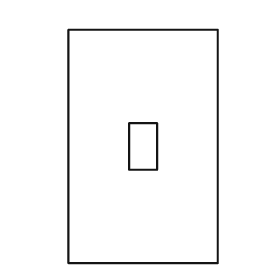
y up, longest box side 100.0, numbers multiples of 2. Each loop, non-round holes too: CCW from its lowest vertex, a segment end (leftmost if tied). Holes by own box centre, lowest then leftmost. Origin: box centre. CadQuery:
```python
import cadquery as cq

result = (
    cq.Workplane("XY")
    .moveTo(-32.0, -50.0)
    .lineTo(32.0, -50.0)
    .lineTo(32.0, 50.0)
    .lineTo(-32.0, 50.0)
    .close()
    .moveTo(-6.0, -10.0)
    .lineTo(6.0, -10.0)
    .lineTo(6.0, 10.0)
    .lineTo(-6.0, 10.0)
    .close()
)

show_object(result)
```